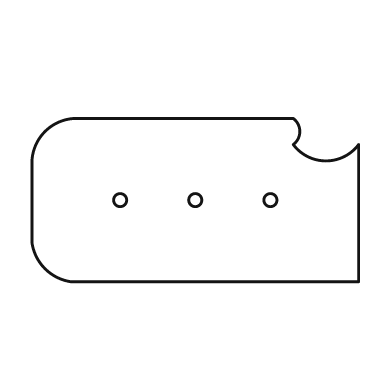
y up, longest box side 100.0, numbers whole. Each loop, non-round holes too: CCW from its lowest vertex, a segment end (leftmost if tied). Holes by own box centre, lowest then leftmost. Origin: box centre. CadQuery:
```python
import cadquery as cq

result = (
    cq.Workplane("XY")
    .moveTo(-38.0, -25.0)
    .lineTo(50.0, -25.0)
    .lineTo(50.0, 17.0)
    .threePointArc((40.0, 12.0), (30.0, 17.0))
    .threePointArc((32.0, 21.0), (30.0, 25.0))
    .lineTo(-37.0, 25.0)
    .threePointArc((-46.0, 21.0), (-50.0, 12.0))
    .lineTo(-50.0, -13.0)
    .threePointArc((-46.0, -21.0), (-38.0, -25.0))
    .close()
    .moveTo(-23.0, 0.0)
    .circle(2.0)
    .moveTo(0.0, 0.0)
    .circle(2.0)
    .moveTo(23.0, 0.0)
    .circle(2.0)
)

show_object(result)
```